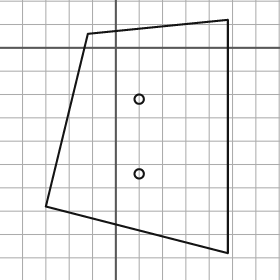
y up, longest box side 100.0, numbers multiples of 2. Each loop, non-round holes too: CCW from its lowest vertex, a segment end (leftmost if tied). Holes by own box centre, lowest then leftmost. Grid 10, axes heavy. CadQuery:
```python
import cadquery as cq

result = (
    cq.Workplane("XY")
    .moveTo(48.0, -88.0)
    .lineTo(48.0, 12.0)
    .lineTo(-12.0, 6.0)
    .lineTo(-30.0, -68.0)
    .close()
    .moveTo(10.0, -54.0)
    .circle(2.0)
    .moveTo(10.0, -22.0)
    .circle(2.0)
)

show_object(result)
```